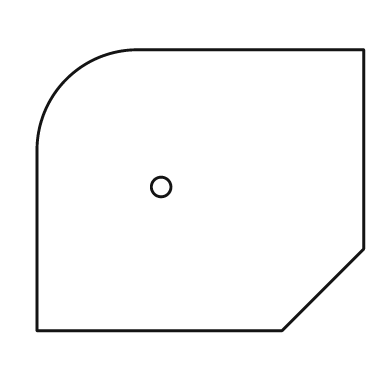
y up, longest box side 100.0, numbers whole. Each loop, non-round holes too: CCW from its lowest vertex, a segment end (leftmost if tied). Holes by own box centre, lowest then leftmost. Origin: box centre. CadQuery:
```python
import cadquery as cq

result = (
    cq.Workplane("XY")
    .moveTo(-50.0, -43.0)
    .lineTo(25.0, -43.0)
    .lineTo(50.0, -18.0)
    .lineTo(50.0, 43.0)
    .lineTo(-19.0, 43.0)
    .threePointArc((-41.0, 34.0), (-50.0, 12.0))
    .close()
    .moveTo(-12.0, 1.0)
    .circle(3.0)
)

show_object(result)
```